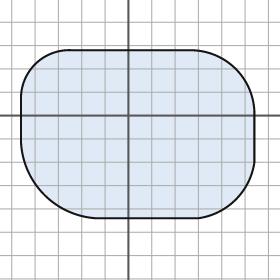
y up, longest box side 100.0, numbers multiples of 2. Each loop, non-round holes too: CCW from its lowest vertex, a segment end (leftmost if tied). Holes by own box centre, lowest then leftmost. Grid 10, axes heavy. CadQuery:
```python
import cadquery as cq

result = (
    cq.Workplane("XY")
    .moveTo(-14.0, -44.0)
    .lineTo(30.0, -44.0)
    .threePointArc((46.0, -36.0), (54.0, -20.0))
    .lineTo(54.0, 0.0)
    .threePointArc((46.0, 20.0), (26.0, 28.0))
    .lineTo(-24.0, 28.0)
    .threePointArc((-40.0, 22.0), (-46.0, 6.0))
    .lineTo(-46.0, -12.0)
    .threePointArc((-36.0, -34.0), (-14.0, -44.0))
    .close()
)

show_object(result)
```